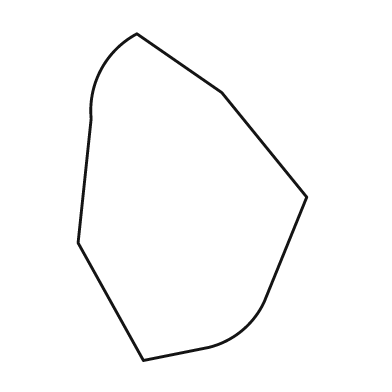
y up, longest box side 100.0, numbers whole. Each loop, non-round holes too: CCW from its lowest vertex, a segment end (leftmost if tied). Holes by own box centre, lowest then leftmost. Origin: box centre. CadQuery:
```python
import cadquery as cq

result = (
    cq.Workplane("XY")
    .moveTo(-15.0, -50.0)
    .lineTo(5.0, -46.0)
    .threePointArc((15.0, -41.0), (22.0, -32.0))
    .lineTo(35.0, 0.0)
    .lineTo(9.0, 32.0)
    .lineTo(-17.0, 50.0)
    .threePointArc((-28.0, 39.0), (-31.0, 24.0))
    .lineTo(-35.0, -14.0)
    .close()
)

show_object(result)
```